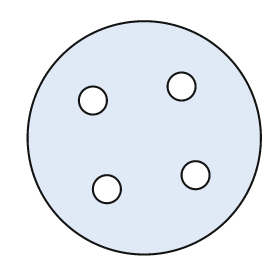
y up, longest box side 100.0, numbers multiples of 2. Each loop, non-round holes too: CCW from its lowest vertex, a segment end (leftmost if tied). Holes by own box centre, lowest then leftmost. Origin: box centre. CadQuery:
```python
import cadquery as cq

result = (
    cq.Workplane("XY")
    .moveTo(0.0, 0.0)
    .circle(50.0)
    .moveTo(-16.0, -22.0)
    .circle(6.0)
    .moveTo(22.0, -16.0)
    .circle(6.0)
    .moveTo(-22.0, 16.0)
    .circle(6.0)
    .moveTo(16.0, 22.0)
    .circle(6.0)
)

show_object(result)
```